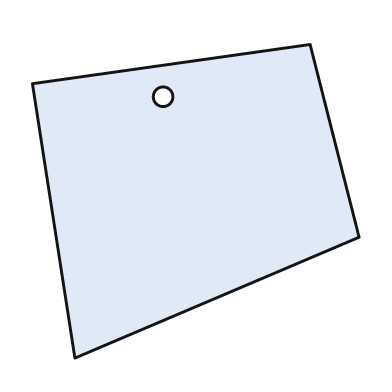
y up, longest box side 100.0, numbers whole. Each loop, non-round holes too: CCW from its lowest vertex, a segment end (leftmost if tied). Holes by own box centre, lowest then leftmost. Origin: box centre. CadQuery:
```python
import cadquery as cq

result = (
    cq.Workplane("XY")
    .moveTo(-37.0, -48.0)
    .lineTo(50.0, -11.0)
    .lineTo(35.0, 48.0)
    .lineTo(-50.0, 36.0)
    .close()
    .moveTo(-10.0, 32.0)
    .circle(3.0)
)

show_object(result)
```